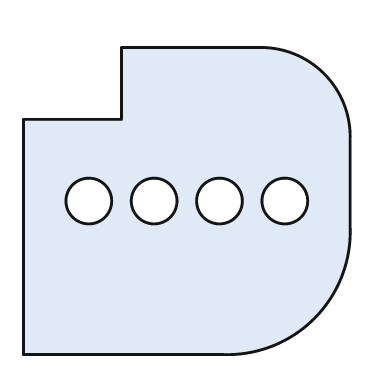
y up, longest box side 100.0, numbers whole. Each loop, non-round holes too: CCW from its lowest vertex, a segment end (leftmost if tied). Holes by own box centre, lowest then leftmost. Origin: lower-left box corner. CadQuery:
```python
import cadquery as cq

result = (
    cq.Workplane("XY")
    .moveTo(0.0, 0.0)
    .lineTo(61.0, 0.0)
    .threePointArc((89.0, 11.0), (100.0, 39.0))
    .lineTo(100.0, 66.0)
    .threePointArc((92.0, 86.0), (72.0, 94.0))
    .lineTo(30.0, 94.0)
    .lineTo(30.0, 72.0)
    .lineTo(0.0, 72.0)
    .close()
    .moveTo(20.0, 47.0)
    .circle(7.0)
    .moveTo(40.0, 47.0)
    .circle(7.0)
    .moveTo(60.0, 47.0)
    .circle(7.0)
    .moveTo(80.0, 47.0)
    .circle(7.0)
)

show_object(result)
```